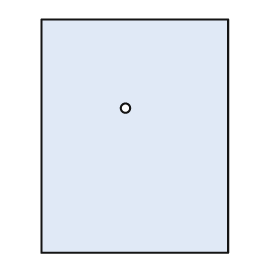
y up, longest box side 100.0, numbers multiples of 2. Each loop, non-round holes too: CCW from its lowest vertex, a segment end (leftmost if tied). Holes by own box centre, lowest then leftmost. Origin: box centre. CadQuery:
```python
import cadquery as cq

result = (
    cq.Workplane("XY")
    .moveTo(-40.0, -50.0)
    .lineTo(40.0, -50.0)
    .lineTo(40.0, 50.0)
    .lineTo(-40.0, 50.0)
    .close()
    .moveTo(-4.0, 12.0)
    .circle(2.0)
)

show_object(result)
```